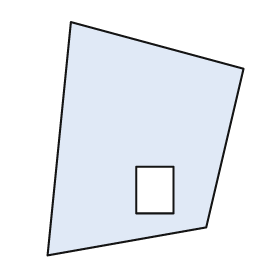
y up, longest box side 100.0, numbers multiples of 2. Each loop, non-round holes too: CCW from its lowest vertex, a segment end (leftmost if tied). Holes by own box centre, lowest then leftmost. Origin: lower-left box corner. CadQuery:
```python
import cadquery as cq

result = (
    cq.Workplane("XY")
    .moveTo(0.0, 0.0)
    .lineTo(68.0, 12.0)
    .lineTo(84.0, 80.0)
    .lineTo(10.0, 100.0)
    .close()
    .moveTo(38.0, 18.0)
    .lineTo(54.0, 18.0)
    .lineTo(54.0, 38.0)
    .lineTo(38.0, 38.0)
    .close()
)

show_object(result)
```